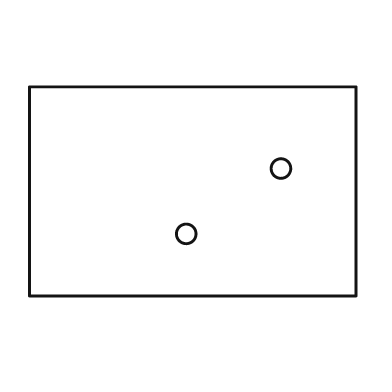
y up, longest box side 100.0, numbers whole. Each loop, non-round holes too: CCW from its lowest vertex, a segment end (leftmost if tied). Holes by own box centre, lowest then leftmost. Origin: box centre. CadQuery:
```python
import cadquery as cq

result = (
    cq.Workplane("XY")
    .moveTo(-50.0, -32.0)
    .lineTo(50.0, -32.0)
    .lineTo(50.0, 32.0)
    .lineTo(-50.0, 32.0)
    .close()
    .moveTo(-2.0, -13.0)
    .circle(3.0)
    .moveTo(27.0, 7.0)
    .circle(3.0)
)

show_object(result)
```